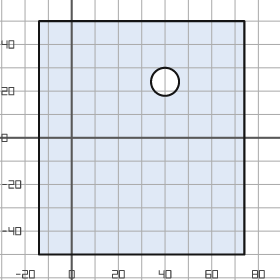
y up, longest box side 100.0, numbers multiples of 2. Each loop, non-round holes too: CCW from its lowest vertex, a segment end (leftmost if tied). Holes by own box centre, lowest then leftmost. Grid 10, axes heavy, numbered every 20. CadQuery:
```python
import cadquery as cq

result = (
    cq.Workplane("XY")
    .moveTo(-14.0, -50.0)
    .lineTo(74.0, -50.0)
    .lineTo(74.0, 50.0)
    .lineTo(-14.0, 50.0)
    .close()
    .moveTo(40.0, 24.0)
    .circle(6.0)
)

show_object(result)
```